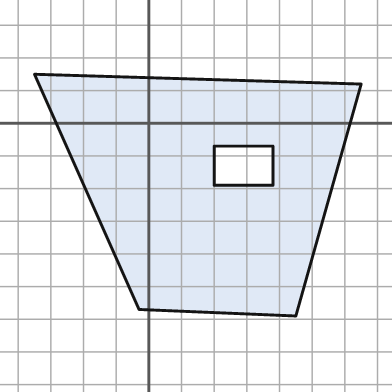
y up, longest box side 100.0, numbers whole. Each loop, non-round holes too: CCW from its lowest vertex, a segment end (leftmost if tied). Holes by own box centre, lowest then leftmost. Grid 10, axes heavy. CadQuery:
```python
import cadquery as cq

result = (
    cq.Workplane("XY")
    .moveTo(45.0, -59.0)
    .lineTo(65.0, 12.0)
    .lineTo(-35.0, 15.0)
    .lineTo(-3.0, -57.0)
    .close()
    .moveTo(20.0, -19.0)
    .lineTo(38.0, -19.0)
    .lineTo(38.0, -7.0)
    .lineTo(20.0, -7.0)
    .close()
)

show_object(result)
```